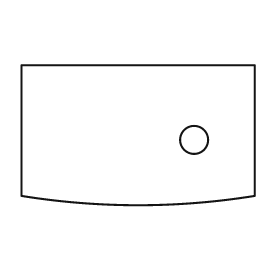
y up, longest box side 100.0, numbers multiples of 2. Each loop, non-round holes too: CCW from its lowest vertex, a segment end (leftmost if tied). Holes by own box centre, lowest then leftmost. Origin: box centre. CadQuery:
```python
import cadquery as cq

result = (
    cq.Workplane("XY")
    .moveTo(-50.0, -26.0)
    .threePointArc((0.0, -30.0), (50.0, -26.0))
    .lineTo(50.0, 30.0)
    .lineTo(-50.0, 30.0)
    .close()
    .moveTo(24.0, -2.0)
    .circle(6.0)
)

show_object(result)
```